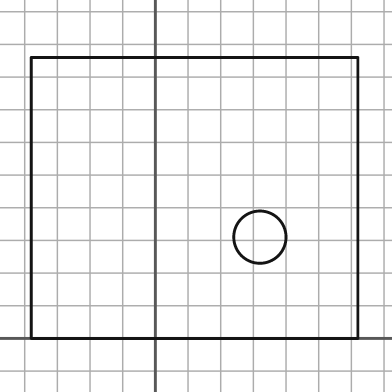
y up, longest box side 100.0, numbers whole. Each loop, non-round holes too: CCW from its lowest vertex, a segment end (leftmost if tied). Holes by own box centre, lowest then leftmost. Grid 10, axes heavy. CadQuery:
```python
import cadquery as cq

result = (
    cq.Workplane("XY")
    .moveTo(-38.0, 0.0)
    .lineTo(62.0, 0.0)
    .lineTo(62.0, 86.0)
    .lineTo(-38.0, 86.0)
    .close()
    .moveTo(32.0, 31.0)
    .circle(8.0)
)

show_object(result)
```